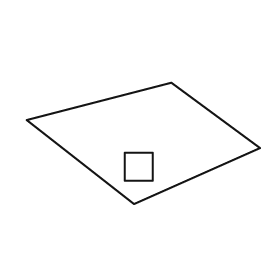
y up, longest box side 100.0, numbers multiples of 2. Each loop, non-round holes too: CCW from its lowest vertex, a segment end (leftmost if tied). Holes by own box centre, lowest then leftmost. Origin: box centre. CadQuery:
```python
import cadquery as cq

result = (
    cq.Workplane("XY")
    .moveTo(-4.0, -26.0)
    .lineTo(50.0, -2.0)
    .lineTo(12.0, 26.0)
    .lineTo(-50.0, 10.0)
    .close()
    .moveTo(-8.0, -16.0)
    .lineTo(4.0, -16.0)
    .lineTo(4.0, -4.0)
    .lineTo(-8.0, -4.0)
    .close()
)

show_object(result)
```